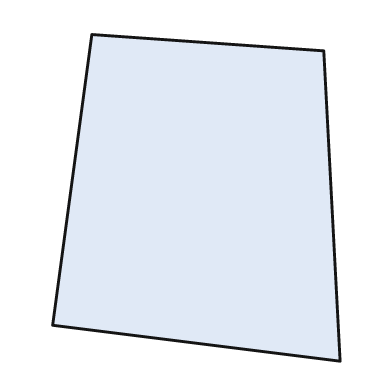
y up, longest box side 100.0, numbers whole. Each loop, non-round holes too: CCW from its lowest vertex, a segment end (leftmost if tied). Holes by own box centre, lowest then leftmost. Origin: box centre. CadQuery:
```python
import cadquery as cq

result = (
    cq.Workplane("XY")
    .moveTo(44.0, -50.0)
    .lineTo(39.0, 45.0)
    .lineTo(-32.0, 50.0)
    .lineTo(-44.0, -39.0)
    .close()
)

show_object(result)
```